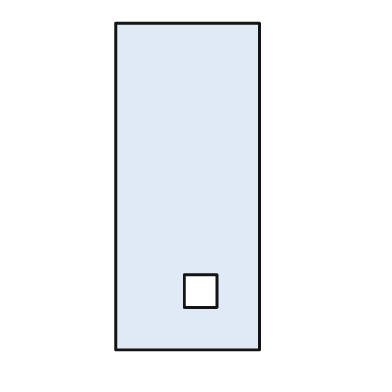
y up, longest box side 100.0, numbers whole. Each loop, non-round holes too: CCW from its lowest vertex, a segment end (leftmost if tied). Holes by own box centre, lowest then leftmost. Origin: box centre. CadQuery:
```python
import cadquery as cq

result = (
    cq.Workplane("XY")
    .moveTo(-22.0, -50.0)
    .lineTo(22.0, -50.0)
    .lineTo(22.0, 50.0)
    .lineTo(-22.0, 50.0)
    .close()
    .moveTo(-1.0, -37.0)
    .lineTo(9.0, -37.0)
    .lineTo(9.0, -27.0)
    .lineTo(-1.0, -27.0)
    .close()
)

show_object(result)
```